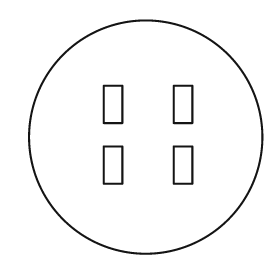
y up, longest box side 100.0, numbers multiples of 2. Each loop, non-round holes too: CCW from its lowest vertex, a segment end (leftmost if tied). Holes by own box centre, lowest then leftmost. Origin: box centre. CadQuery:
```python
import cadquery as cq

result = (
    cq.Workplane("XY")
    .moveTo(0.0, 0.0)
    .circle(50.0)
    .moveTo(-18.0, -20.0)
    .lineTo(-10.0, -20.0)
    .lineTo(-10.0, -4.0)
    .lineTo(-18.0, -4.0)
    .close()
    .moveTo(12.0, -20.0)
    .lineTo(20.0, -20.0)
    .lineTo(20.0, -4.0)
    .lineTo(12.0, -4.0)
    .close()
    .moveTo(-18.0, 6.0)
    .lineTo(-10.0, 6.0)
    .lineTo(-10.0, 22.0)
    .lineTo(-18.0, 22.0)
    .close()
    .moveTo(12.0, 6.0)
    .lineTo(20.0, 6.0)
    .lineTo(20.0, 22.0)
    .lineTo(12.0, 22.0)
    .close()
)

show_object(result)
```